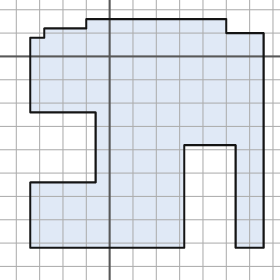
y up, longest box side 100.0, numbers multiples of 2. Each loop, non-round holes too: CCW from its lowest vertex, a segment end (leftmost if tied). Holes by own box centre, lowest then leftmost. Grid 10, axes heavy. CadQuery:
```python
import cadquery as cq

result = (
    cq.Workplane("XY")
    .moveTo(-34.0, -82.0)
    .lineTo(32.0, -82.0)
    .lineTo(32.0, -38.0)
    .lineTo(54.0, -38.0)
    .lineTo(54.0, -82.0)
    .lineTo(66.0, -82.0)
    .lineTo(66.0, 10.0)
    .lineTo(50.0, 10.0)
    .lineTo(50.0, 16.0)
    .lineTo(-10.0, 16.0)
    .lineTo(-10.0, 12.0)
    .lineTo(-28.0, 12.0)
    .lineTo(-28.0, 8.0)
    .lineTo(-34.0, 8.0)
    .lineTo(-34.0, -24.0)
    .lineTo(-6.0, -24.0)
    .lineTo(-6.0, -54.0)
    .lineTo(-34.0, -54.0)
    .close()
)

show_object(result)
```